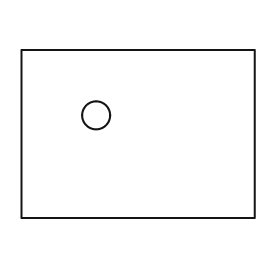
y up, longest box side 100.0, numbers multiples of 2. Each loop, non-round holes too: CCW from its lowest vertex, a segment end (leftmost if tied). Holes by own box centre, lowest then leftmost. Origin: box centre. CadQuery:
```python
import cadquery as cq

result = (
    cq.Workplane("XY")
    .moveTo(-50.0, -36.0)
    .lineTo(50.0, -36.0)
    .lineTo(50.0, 36.0)
    .lineTo(-50.0, 36.0)
    .close()
    .moveTo(-18.0, 8.0)
    .circle(6.0)
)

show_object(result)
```